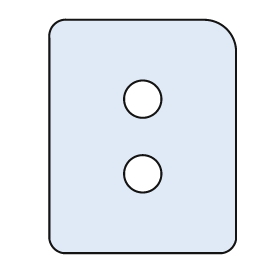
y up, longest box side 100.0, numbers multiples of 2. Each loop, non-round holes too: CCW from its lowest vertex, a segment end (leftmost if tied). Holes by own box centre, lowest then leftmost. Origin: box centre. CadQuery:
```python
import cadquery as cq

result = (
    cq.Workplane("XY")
    .moveTo(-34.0, -50.0)
    .lineTo(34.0, -50.0)
    .threePointArc((38.0, -48.0), (40.0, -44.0))
    .lineTo(40.0, 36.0)
    .threePointArc((36.0, 46.0), (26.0, 50.0))
    .lineTo(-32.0, 50.0)
    .threePointArc((-38.0, 48.0), (-40.0, 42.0))
    .lineTo(-40.0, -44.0)
    .threePointArc((-38.0, -48.0), (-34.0, -50.0))
    .close()
    .moveTo(0.0, -16.0)
    .circle(8.0)
    .moveTo(0.0, 16.0)
    .circle(8.0)
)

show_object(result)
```